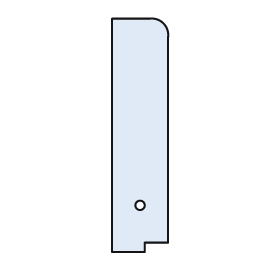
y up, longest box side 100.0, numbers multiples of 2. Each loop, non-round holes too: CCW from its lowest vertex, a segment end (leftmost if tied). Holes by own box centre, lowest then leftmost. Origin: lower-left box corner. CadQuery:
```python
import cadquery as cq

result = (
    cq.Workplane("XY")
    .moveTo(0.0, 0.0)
    .lineTo(14.0, 0.0)
    .lineTo(14.0, 4.0)
    .lineTo(24.0, 4.0)
    .lineTo(24.0, 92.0)
    .threePointArc((22.0, 98.0), (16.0, 100.0))
    .lineTo(0.0, 100.0)
    .close()
    .moveTo(12.0, 20.0)
    .circle(2.0)
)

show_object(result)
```